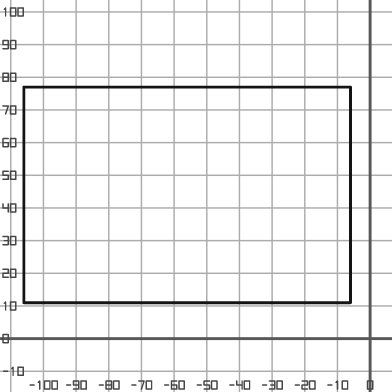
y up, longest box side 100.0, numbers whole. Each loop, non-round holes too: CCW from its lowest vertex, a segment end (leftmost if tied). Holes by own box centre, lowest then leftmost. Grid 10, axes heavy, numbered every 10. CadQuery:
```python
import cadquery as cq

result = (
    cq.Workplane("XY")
    .moveTo(-106.0, 11.0)
    .lineTo(-6.0, 11.0)
    .lineTo(-6.0, 77.0)
    .lineTo(-106.0, 77.0)
    .close()
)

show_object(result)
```